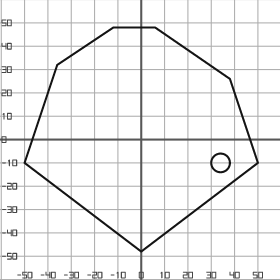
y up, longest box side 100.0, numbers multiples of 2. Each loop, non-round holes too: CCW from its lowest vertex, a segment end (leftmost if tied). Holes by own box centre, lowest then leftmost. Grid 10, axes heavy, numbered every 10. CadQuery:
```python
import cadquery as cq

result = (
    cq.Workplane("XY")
    .moveTo(0.0, -48.0)
    .lineTo(50.0, -10.0)
    .lineTo(38.0, 26.0)
    .lineTo(6.0, 48.0)
    .lineTo(-12.0, 48.0)
    .lineTo(-36.0, 32.0)
    .lineTo(-50.0, -10.0)
    .close()
    .moveTo(34.0, -10.0)
    .circle(4.0)
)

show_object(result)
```